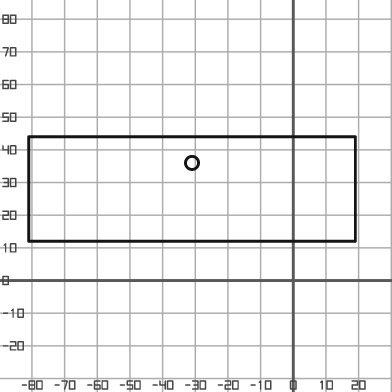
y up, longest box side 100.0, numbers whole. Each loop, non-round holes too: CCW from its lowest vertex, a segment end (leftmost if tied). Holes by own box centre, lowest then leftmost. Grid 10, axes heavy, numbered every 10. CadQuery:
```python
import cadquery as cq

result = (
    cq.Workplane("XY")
    .moveTo(-81.0, 12.0)
    .lineTo(19.0, 12.0)
    .lineTo(19.0, 44.0)
    .lineTo(-81.0, 44.0)
    .close()
    .moveTo(-31.0, 36.0)
    .circle(2.0)
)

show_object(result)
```